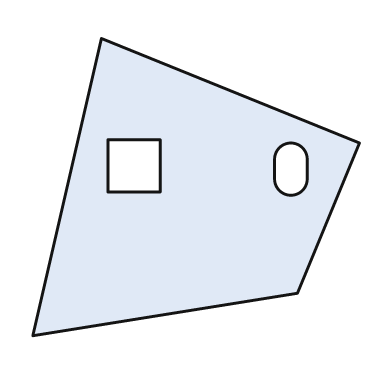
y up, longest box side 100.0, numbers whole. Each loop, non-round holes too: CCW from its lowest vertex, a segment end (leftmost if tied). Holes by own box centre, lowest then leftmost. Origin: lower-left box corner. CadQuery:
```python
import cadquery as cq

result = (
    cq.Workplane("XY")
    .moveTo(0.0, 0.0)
    .lineTo(81.0, 13.0)
    .lineTo(100.0, 59.0)
    .lineTo(21.0, 91.0)
    .close()
    .moveTo(74.0, 48.0)
    .threePointArc((79.0, 43.0), (84.0, 48.0))
    .lineTo(84.0, 54.0)
    .threePointArc((79.0, 59.0), (74.0, 54.0))
    .close()
    .moveTo(23.0, 44.0)
    .lineTo(39.0, 44.0)
    .lineTo(39.0, 60.0)
    .lineTo(23.0, 60.0)
    .close()
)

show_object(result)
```